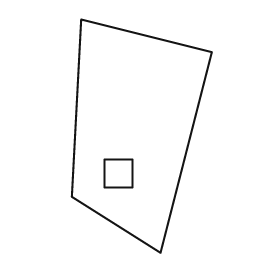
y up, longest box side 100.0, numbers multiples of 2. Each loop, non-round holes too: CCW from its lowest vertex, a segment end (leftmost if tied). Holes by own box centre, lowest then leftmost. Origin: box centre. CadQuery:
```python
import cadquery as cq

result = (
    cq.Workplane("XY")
    .moveTo(8.0, -50.0)
    .lineTo(30.0, 36.0)
    .lineTo(-26.0, 50.0)
    .lineTo(-30.0, -26.0)
    .close()
    .moveTo(-16.0, -22.0)
    .lineTo(-4.0, -22.0)
    .lineTo(-4.0, -10.0)
    .lineTo(-16.0, -10.0)
    .close()
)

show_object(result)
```